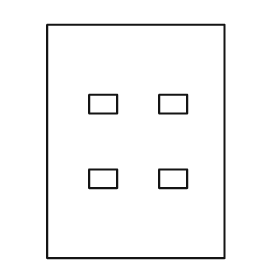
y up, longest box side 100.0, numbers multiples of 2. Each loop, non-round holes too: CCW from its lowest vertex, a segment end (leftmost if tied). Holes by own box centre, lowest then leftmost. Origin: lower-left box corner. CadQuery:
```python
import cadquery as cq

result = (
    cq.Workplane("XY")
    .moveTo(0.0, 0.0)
    .lineTo(76.0, 0.0)
    .lineTo(76.0, 100.0)
    .lineTo(0.0, 100.0)
    .close()
    .moveTo(18.0, 30.0)
    .lineTo(30.0, 30.0)
    .lineTo(30.0, 38.0)
    .lineTo(18.0, 38.0)
    .close()
    .moveTo(48.0, 30.0)
    .lineTo(60.0, 30.0)
    .lineTo(60.0, 38.0)
    .lineTo(48.0, 38.0)
    .close()
    .moveTo(18.0, 62.0)
    .lineTo(30.0, 62.0)
    .lineTo(30.0, 70.0)
    .lineTo(18.0, 70.0)
    .close()
    .moveTo(48.0, 62.0)
    .lineTo(60.0, 62.0)
    .lineTo(60.0, 70.0)
    .lineTo(48.0, 70.0)
    .close()
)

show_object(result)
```